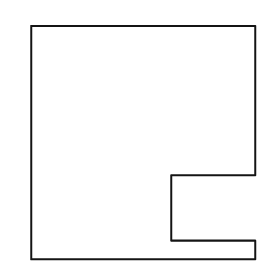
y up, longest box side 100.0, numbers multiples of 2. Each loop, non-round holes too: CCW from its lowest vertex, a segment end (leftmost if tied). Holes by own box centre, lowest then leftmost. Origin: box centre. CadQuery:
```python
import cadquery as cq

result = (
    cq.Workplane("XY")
    .moveTo(-48.0, -50.0)
    .lineTo(48.0, -50.0)
    .lineTo(48.0, -42.0)
    .lineTo(12.0, -42.0)
    .lineTo(12.0, -14.0)
    .lineTo(48.0, -14.0)
    .lineTo(48.0, 50.0)
    .lineTo(-48.0, 50.0)
    .close()
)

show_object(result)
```